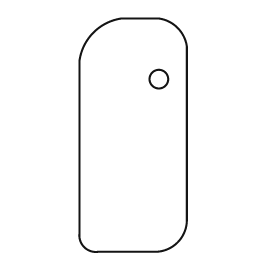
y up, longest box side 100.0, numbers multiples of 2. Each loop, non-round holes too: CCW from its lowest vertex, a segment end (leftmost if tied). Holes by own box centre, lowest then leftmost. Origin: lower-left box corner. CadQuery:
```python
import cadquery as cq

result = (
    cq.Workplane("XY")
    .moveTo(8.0, 0.0)
    .lineTo(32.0, 0.0)
    .threePointArc((42.0, 4.0), (46.0, 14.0))
    .lineTo(46.0, 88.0)
    .threePointArc((42.0, 96.0), (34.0, 100.0))
    .lineTo(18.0, 100.0)
    .threePointArc((6.0, 94.0), (0.0, 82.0))
    .lineTo(0.0, 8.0)
    .threePointArc((2.0, 2.0), (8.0, 0.0))
    .close()
    .moveTo(34.0, 74.0)
    .circle(4.0)
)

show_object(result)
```